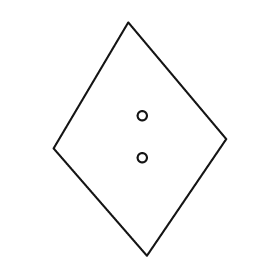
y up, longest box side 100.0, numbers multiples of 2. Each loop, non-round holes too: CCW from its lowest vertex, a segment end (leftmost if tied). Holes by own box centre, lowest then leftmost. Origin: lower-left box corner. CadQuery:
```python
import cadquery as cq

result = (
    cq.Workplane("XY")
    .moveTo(40.0, 0.0)
    .lineTo(74.0, 50.0)
    .lineTo(32.0, 100.0)
    .lineTo(0.0, 46.0)
    .close()
    .moveTo(38.0, 42.0)
    .circle(2.0)
    .moveTo(38.0, 60.0)
    .circle(2.0)
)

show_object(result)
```